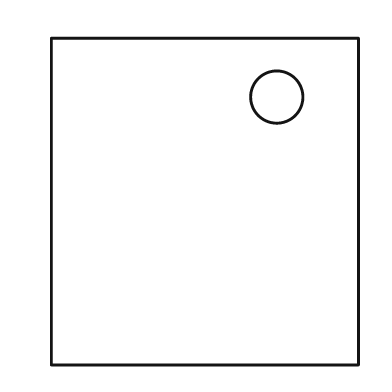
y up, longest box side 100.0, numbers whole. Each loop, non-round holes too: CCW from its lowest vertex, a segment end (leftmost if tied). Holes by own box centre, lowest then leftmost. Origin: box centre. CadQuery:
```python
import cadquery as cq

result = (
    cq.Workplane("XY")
    .moveTo(-47.0, -50.0)
    .lineTo(47.0, -50.0)
    .lineTo(47.0, 50.0)
    .lineTo(-47.0, 50.0)
    .close()
    .moveTo(22.0, 32.0)
    .circle(8.0)
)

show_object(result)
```